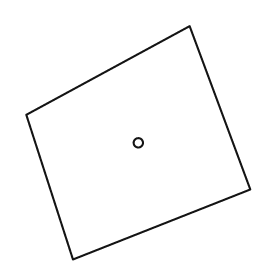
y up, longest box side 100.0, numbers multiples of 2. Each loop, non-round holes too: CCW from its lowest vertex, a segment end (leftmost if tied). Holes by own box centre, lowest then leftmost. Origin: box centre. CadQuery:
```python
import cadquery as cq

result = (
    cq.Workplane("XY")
    .moveTo(-28.0, -50.0)
    .lineTo(48.0, -20.0)
    .lineTo(22.0, 50.0)
    .lineTo(-48.0, 12.0)
    .close()
    .moveTo(0.0, 0.0)
    .circle(2.0)
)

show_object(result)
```